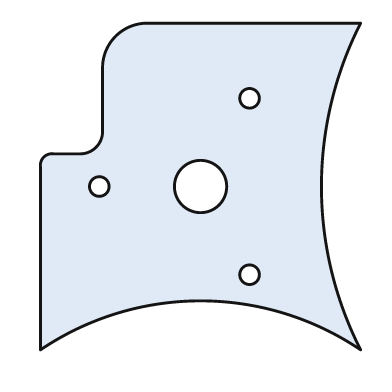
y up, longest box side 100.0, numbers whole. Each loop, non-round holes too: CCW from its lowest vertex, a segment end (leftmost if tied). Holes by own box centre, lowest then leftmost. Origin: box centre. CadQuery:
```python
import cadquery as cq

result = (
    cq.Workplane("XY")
    .moveTo(-49.0, -50.0)
    .threePointArc((0.0, -35.0), (49.0, -50.0))
    .threePointArc((37.0, 0.0), (49.0, 50.0))
    .lineTo(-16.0, 50.0)
    .threePointArc((-26.0, 46.0), (-30.0, 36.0))
    .lineTo(-30.0, 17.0)
    .threePointArc((-32.0, 12.0), (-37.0, 10.0))
    .lineTo(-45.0, 10.0)
    .threePointArc((-48.0, 9.0), (-49.0, 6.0))
    .close()
    .moveTo(15.0, -27.0)
    .circle(3.0)
    .moveTo(-31.0, 0.0)
    .circle(3.0)
    .moveTo(0.0, 0.0)
    .circle(8.0)
    .moveTo(15.0, 27.0)
    .circle(3.0)
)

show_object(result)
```